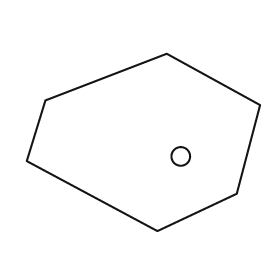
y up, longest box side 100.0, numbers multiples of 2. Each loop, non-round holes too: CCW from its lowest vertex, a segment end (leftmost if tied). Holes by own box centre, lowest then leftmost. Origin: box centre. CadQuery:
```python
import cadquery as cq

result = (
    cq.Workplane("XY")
    .moveTo(6.0, -38.0)
    .lineTo(40.0, -22.0)
    .lineTo(50.0, 16.0)
    .lineTo(10.0, 38.0)
    .lineTo(-42.0, 18.0)
    .lineTo(-50.0, -8.0)
    .close()
    .moveTo(16.0, -6.0)
    .circle(4.0)
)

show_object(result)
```